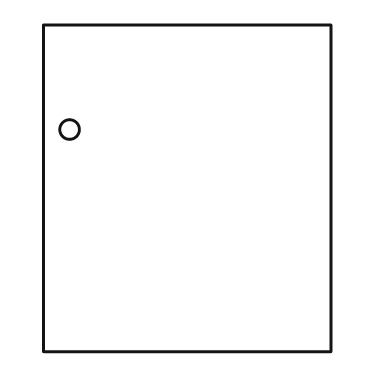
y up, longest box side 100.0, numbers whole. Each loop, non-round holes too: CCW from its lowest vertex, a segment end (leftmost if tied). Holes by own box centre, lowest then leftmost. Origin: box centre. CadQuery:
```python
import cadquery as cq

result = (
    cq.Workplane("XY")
    .moveTo(-44.0, -50.0)
    .lineTo(44.0, -50.0)
    .lineTo(44.0, 50.0)
    .lineTo(-44.0, 50.0)
    .close()
    .moveTo(-36.0, 18.0)
    .circle(3.0)
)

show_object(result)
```